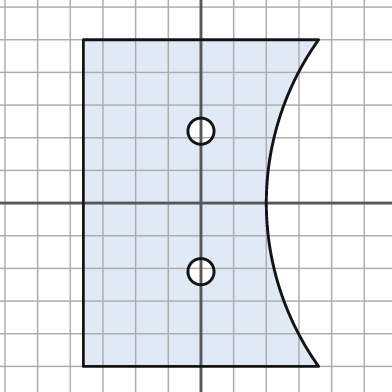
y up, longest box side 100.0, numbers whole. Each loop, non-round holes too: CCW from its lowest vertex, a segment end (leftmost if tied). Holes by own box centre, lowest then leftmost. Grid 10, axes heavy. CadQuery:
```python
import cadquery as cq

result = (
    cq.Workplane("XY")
    .moveTo(-36.0, -50.0)
    .lineTo(36.0, -50.0)
    .threePointArc((20.0, 0.0), (36.0, 50.0))
    .lineTo(-36.0, 50.0)
    .close()
    .moveTo(0.0, -21.0)
    .circle(4.0)
    .moveTo(0.0, 22.0)
    .circle(4.0)
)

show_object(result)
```